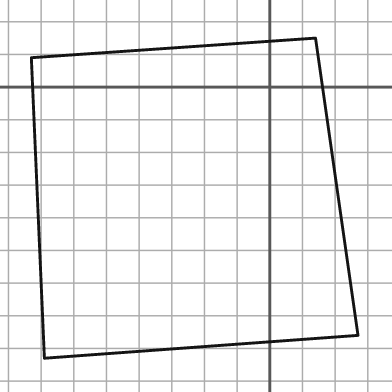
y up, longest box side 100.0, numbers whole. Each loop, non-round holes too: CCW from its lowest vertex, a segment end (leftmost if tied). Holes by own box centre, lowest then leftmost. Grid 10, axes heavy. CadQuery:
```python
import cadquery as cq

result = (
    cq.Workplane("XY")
    .moveTo(-69.0, -83.0)
    .lineTo(27.0, -76.0)
    .lineTo(14.0, 15.0)
    .lineTo(-73.0, 9.0)
    .close()
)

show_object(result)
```